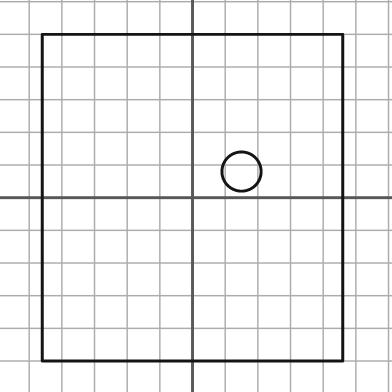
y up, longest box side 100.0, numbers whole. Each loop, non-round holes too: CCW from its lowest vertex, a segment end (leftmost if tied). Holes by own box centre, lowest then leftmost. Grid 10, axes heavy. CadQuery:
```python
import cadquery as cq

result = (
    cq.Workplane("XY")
    .moveTo(-46.0, -50.0)
    .lineTo(46.0, -50.0)
    .lineTo(46.0, 50.0)
    .lineTo(-46.0, 50.0)
    .close()
    .moveTo(15.0, 8.0)
    .circle(6.0)
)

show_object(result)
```